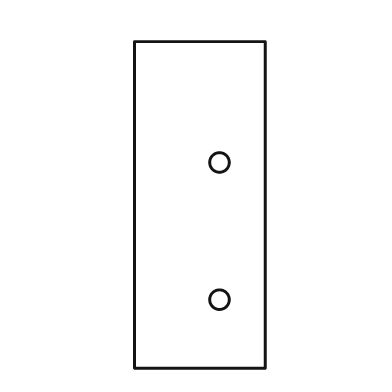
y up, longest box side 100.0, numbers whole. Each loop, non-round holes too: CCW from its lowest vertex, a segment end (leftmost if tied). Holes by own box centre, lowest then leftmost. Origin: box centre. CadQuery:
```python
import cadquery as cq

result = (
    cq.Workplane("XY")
    .moveTo(-20.0, -50.0)
    .lineTo(20.0, -50.0)
    .lineTo(20.0, 50.0)
    .lineTo(-20.0, 50.0)
    .close()
    .moveTo(6.0, -29.0)
    .circle(3.0)
    .moveTo(6.0, 13.0)
    .circle(3.0)
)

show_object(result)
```